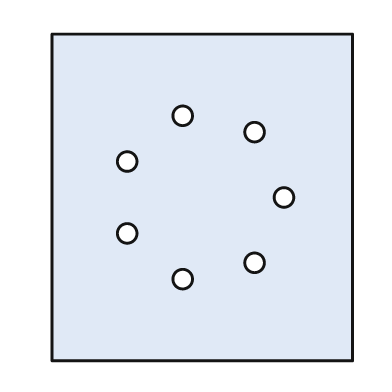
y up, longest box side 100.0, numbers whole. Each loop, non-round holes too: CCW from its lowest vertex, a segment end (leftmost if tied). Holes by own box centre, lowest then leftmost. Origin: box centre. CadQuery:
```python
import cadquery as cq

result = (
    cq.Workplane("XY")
    .moveTo(-46.0, -50.0)
    .lineTo(46.0, -50.0)
    .lineTo(46.0, 50.0)
    .lineTo(-46.0, 50.0)
    .close()
    .moveTo(-6.0, -25.0)
    .circle(3.0)
    .moveTo(16.0, -20.0)
    .circle(3.0)
    .moveTo(-23.0, -11.0)
    .circle(3.0)
    .moveTo(25.0, 0.0)
    .circle(3.0)
    .moveTo(-23.0, 11.0)
    .circle(3.0)
    .moveTo(16.0, 20.0)
    .circle(3.0)
    .moveTo(-6.0, 25.0)
    .circle(3.0)
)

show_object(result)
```